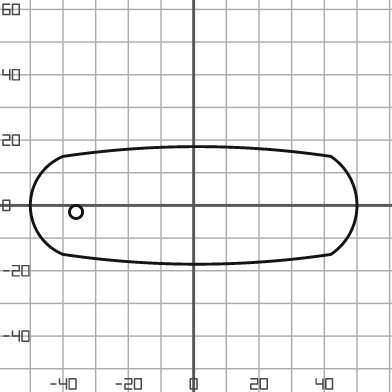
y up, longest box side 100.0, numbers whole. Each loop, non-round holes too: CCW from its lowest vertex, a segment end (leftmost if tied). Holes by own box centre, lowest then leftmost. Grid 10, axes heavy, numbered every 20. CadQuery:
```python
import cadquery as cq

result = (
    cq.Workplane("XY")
    .moveTo(-40.0, -15.0)
    .threePointArc((1.0, -18.0), (42.0, -15.0))
    .threePointArc((50.0, 0.0), (42.0, 15.0))
    .threePointArc((1.0, 18.0), (-40.0, 15.0))
    .threePointArc((-50.0, 0.0), (-40.0, -15.0))
    .close()
    .moveTo(-36.0, -2.0)
    .circle(2.0)
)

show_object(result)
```